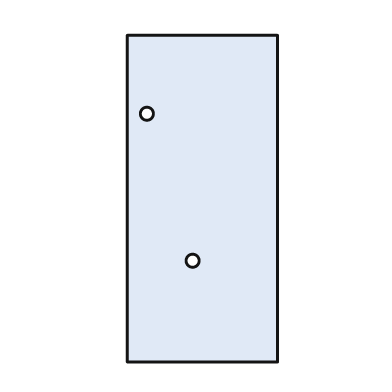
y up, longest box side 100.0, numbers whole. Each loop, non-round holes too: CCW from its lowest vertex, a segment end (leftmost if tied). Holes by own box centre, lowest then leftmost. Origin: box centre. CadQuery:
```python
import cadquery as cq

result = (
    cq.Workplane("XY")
    .moveTo(-23.0, -50.0)
    .lineTo(23.0, -50.0)
    .lineTo(23.0, 50.0)
    .lineTo(-23.0, 50.0)
    .close()
    .moveTo(-3.0, -19.0)
    .circle(2.0)
    .moveTo(-17.0, 26.0)
    .circle(2.0)
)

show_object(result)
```